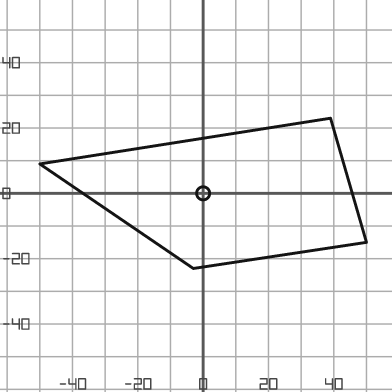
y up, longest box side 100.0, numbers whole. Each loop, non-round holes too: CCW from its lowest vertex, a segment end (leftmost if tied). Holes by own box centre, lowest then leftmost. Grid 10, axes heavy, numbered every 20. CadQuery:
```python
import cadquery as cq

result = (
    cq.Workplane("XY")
    .moveTo(-3.0, -23.0)
    .lineTo(50.0, -15.0)
    .lineTo(39.0, 23.0)
    .lineTo(-50.0, 9.0)
    .close()
    .moveTo(0.0, 0.0)
    .circle(2.0)
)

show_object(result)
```